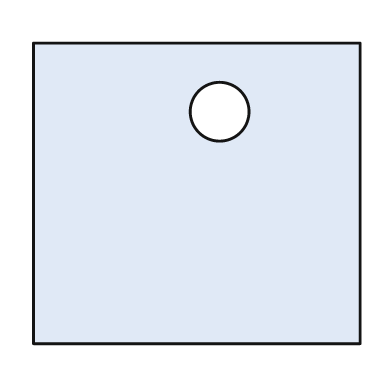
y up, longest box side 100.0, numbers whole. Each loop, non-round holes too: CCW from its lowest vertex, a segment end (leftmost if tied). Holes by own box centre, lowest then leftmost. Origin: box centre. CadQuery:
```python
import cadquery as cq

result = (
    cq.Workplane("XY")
    .moveTo(-50.0, -46.0)
    .lineTo(50.0, -46.0)
    .lineTo(50.0, 46.0)
    .lineTo(-50.0, 46.0)
    .close()
    .moveTo(7.0, 25.0)
    .circle(9.0)
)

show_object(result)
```